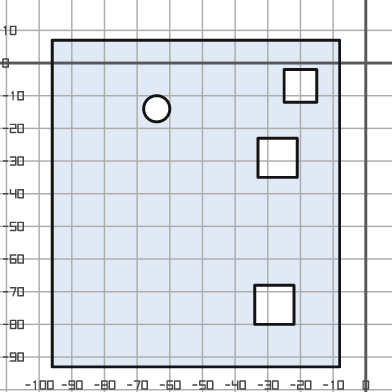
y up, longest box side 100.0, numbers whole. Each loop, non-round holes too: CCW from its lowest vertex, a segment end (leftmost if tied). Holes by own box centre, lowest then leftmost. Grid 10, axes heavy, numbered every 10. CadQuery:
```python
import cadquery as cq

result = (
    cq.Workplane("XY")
    .moveTo(-96.0, -93.0)
    .lineTo(-8.0, -93.0)
    .lineTo(-8.0, 7.0)
    .lineTo(-96.0, 7.0)
    .close()
    .moveTo(-34.0, -80.0)
    .lineTo(-22.0, -80.0)
    .lineTo(-22.0, -68.0)
    .lineTo(-34.0, -68.0)
    .close()
    .moveTo(-33.0, -35.0)
    .lineTo(-21.0, -35.0)
    .lineTo(-21.0, -23.0)
    .lineTo(-33.0, -23.0)
    .close()
    .moveTo(-64.0, -14.0)
    .circle(4.0)
    .moveTo(-25.0, -12.0)
    .lineTo(-15.0, -12.0)
    .lineTo(-15.0, -2.0)
    .lineTo(-25.0, -2.0)
    .close()
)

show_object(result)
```